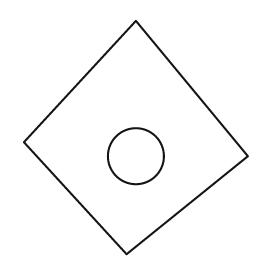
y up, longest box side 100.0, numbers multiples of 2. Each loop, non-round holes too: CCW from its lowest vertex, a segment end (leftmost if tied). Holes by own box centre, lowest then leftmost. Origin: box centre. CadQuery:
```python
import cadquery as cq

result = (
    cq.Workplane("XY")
    .moveTo(-4.0, -50.0)
    .lineTo(48.0, -8.0)
    .lineTo(0.0, 50.0)
    .lineTo(-48.0, -2.0)
    .close()
    .moveTo(0.0, -8.0)
    .circle(12.0)
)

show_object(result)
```